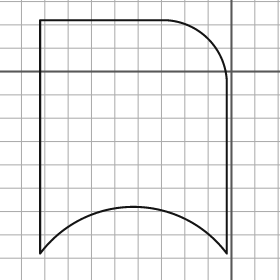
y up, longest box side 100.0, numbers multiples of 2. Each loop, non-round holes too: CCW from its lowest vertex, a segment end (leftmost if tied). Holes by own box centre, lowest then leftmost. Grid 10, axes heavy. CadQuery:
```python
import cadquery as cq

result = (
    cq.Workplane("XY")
    .moveTo(-82.0, -78.0)
    .threePointArc((-42.0, -58.0), (-2.0, -78.0))
    .lineTo(-2.0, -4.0)
    .threePointArc((-10.0, 14.0), (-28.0, 22.0))
    .lineTo(-82.0, 22.0)
    .close()
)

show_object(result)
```